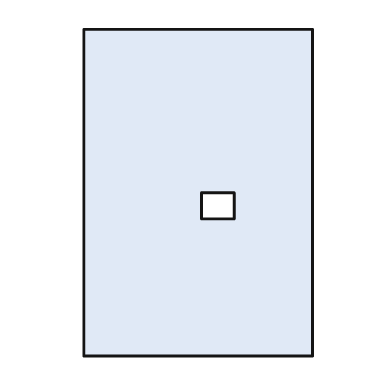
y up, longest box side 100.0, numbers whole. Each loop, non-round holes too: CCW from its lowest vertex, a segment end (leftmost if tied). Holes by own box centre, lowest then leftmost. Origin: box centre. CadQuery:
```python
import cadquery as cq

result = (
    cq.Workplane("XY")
    .moveTo(-35.0, -50.0)
    .lineTo(35.0, -50.0)
    .lineTo(35.0, 50.0)
    .lineTo(-35.0, 50.0)
    .close()
    .moveTo(1.0, -8.0)
    .lineTo(11.0, -8.0)
    .lineTo(11.0, 0.0)
    .lineTo(1.0, 0.0)
    .close()
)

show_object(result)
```